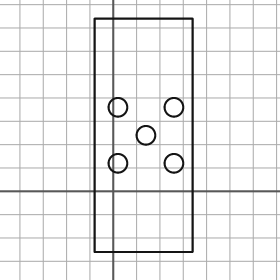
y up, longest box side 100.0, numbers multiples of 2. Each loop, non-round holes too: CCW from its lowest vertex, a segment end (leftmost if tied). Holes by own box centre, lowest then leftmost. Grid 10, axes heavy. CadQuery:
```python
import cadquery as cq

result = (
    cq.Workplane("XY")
    .moveTo(-8.0, -26.0)
    .lineTo(34.0, -26.0)
    .lineTo(34.0, 74.0)
    .lineTo(-8.0, 74.0)
    .close()
    .moveTo(2.0, 12.0)
    .circle(4.0)
    .moveTo(26.0, 12.0)
    .circle(4.0)
    .moveTo(14.0, 24.0)
    .circle(4.0)
    .moveTo(2.0, 36.0)
    .circle(4.0)
    .moveTo(26.0, 36.0)
    .circle(4.0)
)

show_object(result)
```